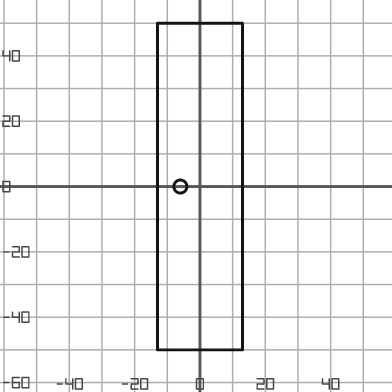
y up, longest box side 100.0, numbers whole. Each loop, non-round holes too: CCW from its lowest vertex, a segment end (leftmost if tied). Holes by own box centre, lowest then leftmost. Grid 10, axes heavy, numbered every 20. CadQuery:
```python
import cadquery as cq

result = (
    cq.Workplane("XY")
    .moveTo(-13.0, -50.0)
    .lineTo(13.0, -50.0)
    .lineTo(13.0, 50.0)
    .lineTo(-13.0, 50.0)
    .close()
    .moveTo(-6.0, 0.0)
    .circle(2.0)
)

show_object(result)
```